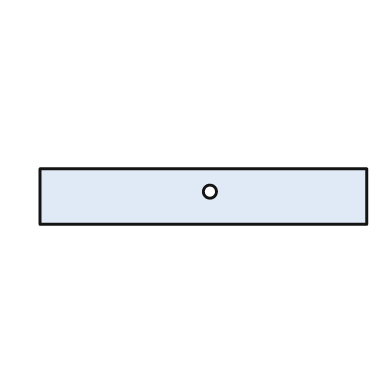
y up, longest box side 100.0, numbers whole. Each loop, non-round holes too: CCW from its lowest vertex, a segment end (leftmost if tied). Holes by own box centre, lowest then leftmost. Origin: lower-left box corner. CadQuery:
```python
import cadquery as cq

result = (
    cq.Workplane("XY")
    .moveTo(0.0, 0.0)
    .lineTo(100.0, 0.0)
    .lineTo(100.0, 17.0)
    .lineTo(0.0, 17.0)
    .close()
    .moveTo(52.0, 10.0)
    .circle(2.0)
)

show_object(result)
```